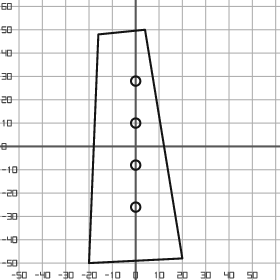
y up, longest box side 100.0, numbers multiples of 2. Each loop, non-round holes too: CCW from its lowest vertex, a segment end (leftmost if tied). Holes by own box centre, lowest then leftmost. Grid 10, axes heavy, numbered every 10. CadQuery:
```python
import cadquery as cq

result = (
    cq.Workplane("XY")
    .moveTo(-20.0, -50.0)
    .lineTo(20.0, -48.0)
    .lineTo(4.0, 50.0)
    .lineTo(-16.0, 48.0)
    .close()
    .moveTo(0.0, -26.0)
    .circle(2.0)
    .moveTo(0.0, -8.0)
    .circle(2.0)
    .moveTo(0.0, 10.0)
    .circle(2.0)
    .moveTo(0.0, 28.0)
    .circle(2.0)
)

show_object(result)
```